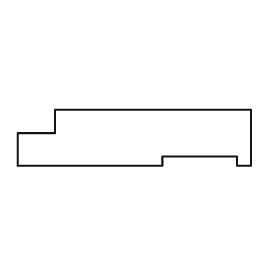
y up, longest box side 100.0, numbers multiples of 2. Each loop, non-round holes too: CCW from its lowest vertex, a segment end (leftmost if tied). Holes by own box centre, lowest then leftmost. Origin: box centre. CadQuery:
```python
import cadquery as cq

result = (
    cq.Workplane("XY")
    .moveTo(-50.0, -12.0)
    .lineTo(12.0, -12.0)
    .lineTo(12.0, -8.0)
    .lineTo(44.0, -8.0)
    .lineTo(44.0, -12.0)
    .lineTo(50.0, -12.0)
    .lineTo(50.0, 12.0)
    .lineTo(-34.0, 12.0)
    .lineTo(-34.0, 2.0)
    .lineTo(-50.0, 2.0)
    .close()
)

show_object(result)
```